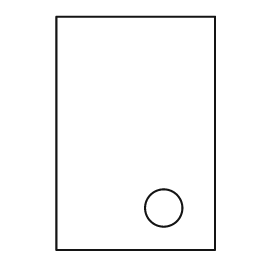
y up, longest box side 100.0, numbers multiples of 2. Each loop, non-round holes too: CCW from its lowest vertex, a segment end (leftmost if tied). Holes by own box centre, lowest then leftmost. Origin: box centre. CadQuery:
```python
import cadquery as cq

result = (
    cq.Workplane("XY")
    .moveTo(-34.0, -50.0)
    .lineTo(34.0, -50.0)
    .lineTo(34.0, 50.0)
    .lineTo(-34.0, 50.0)
    .close()
    .moveTo(12.0, -32.0)
    .circle(8.0)
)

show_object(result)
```